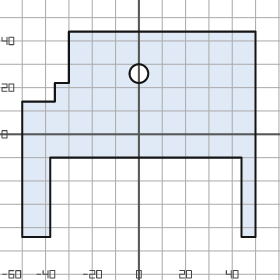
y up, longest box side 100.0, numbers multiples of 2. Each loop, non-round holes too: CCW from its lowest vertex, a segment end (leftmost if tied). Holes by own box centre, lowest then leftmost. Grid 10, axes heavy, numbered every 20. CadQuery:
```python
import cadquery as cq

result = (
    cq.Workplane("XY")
    .moveTo(-50.0, -44.0)
    .lineTo(-38.0, -44.0)
    .lineTo(-38.0, -10.0)
    .lineTo(44.0, -10.0)
    .lineTo(44.0, -44.0)
    .lineTo(50.0, -44.0)
    .lineTo(50.0, 44.0)
    .lineTo(-30.0, 44.0)
    .lineTo(-30.0, 22.0)
    .lineTo(-36.0, 22.0)
    .lineTo(-36.0, 14.0)
    .lineTo(-50.0, 14.0)
    .close()
    .moveTo(0.0, 26.0)
    .circle(4.0)
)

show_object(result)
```